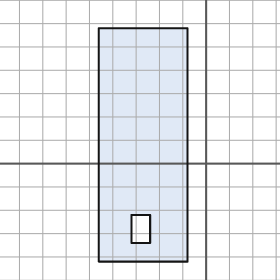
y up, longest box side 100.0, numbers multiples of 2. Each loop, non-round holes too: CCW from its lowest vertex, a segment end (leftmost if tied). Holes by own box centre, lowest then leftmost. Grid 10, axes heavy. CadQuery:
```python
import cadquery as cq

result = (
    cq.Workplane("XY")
    .moveTo(-46.0, -42.0)
    .lineTo(-8.0, -42.0)
    .lineTo(-8.0, 58.0)
    .lineTo(-46.0, 58.0)
    .close()
    .moveTo(-32.0, -34.0)
    .lineTo(-24.0, -34.0)
    .lineTo(-24.0, -22.0)
    .lineTo(-32.0, -22.0)
    .close()
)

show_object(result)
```